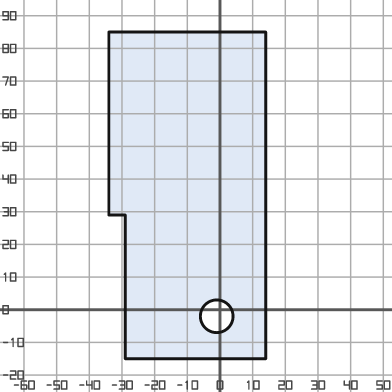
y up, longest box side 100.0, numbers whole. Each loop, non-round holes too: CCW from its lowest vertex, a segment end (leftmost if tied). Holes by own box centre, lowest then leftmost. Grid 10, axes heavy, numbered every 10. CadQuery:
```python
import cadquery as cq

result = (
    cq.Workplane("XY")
    .moveTo(-29.0, -15.0)
    .lineTo(14.0, -15.0)
    .lineTo(14.0, 85.0)
    .lineTo(-34.0, 85.0)
    .lineTo(-34.0, 29.0)
    .lineTo(-29.0, 29.0)
    .close()
    .moveTo(-1.0, -2.0)
    .circle(5.0)
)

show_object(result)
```